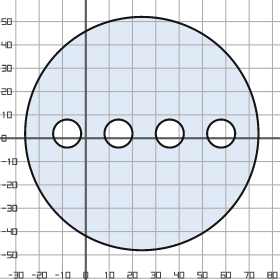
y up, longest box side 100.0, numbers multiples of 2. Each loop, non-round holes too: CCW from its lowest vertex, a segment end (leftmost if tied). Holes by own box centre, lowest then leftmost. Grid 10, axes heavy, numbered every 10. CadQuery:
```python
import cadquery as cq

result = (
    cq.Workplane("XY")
    .moveTo(24.0, 2.0)
    .circle(50.0)
    .moveTo(-8.0, 2.0)
    .circle(6.0)
    .moveTo(14.0, 2.0)
    .circle(6.0)
    .moveTo(36.0, 2.0)
    .circle(6.0)
    .moveTo(58.0, 2.0)
    .circle(6.0)
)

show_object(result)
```